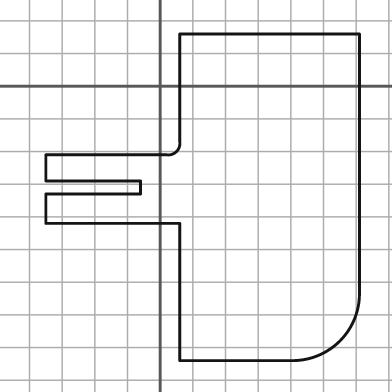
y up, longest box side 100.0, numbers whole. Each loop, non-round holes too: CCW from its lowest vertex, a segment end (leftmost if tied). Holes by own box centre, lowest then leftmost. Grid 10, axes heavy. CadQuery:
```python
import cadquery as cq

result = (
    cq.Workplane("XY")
    .moveTo(6.0, -84.0)
    .lineTo(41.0, -84.0)
    .threePointArc((55.0, -78.0), (61.0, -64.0))
    .lineTo(61.0, 16.0)
    .lineTo(6.0, 16.0)
    .lineTo(6.0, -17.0)
    .threePointArc((5.0, -20.0), (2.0, -21.0))
    .lineTo(-35.0, -21.0)
    .lineTo(-35.0, -29.0)
    .lineTo(-6.0, -29.0)
    .lineTo(-6.0, -33.0)
    .lineTo(-35.0, -33.0)
    .lineTo(-35.0, -42.0)
    .lineTo(6.0, -42.0)
    .close()
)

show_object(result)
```